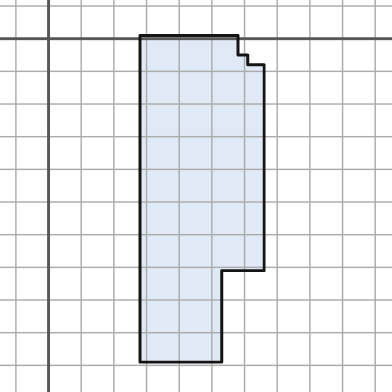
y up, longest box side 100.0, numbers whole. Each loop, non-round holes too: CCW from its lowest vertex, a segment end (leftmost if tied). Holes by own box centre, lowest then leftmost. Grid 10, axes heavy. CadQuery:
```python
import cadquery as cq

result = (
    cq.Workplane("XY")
    .moveTo(28.0, -99.0)
    .lineTo(53.0, -99.0)
    .lineTo(53.0, -71.0)
    .lineTo(66.0, -71.0)
    .lineTo(66.0, -8.0)
    .lineTo(61.0, -8.0)
    .lineTo(61.0, -5.0)
    .lineTo(58.0, -5.0)
    .lineTo(58.0, 1.0)
    .lineTo(28.0, 1.0)
    .close()
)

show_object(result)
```